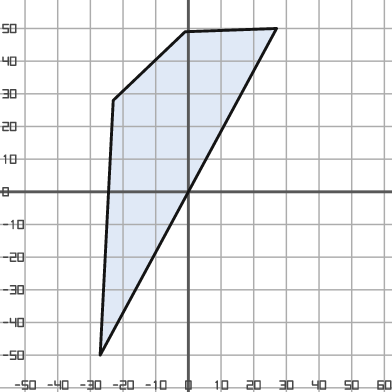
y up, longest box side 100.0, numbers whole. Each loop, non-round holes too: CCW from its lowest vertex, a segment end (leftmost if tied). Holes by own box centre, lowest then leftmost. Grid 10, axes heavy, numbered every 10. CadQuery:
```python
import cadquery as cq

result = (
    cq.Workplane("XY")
    .moveTo(-27.0, -50.0)
    .lineTo(27.0, 50.0)
    .lineTo(-1.0, 49.0)
    .lineTo(-23.0, 28.0)
    .close()
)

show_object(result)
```